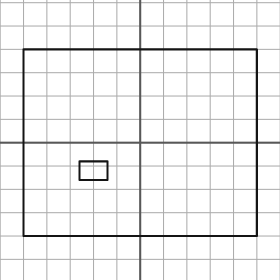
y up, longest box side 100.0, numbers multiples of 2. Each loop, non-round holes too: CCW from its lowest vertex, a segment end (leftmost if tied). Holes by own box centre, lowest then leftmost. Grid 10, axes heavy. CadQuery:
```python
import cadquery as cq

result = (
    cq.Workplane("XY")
    .moveTo(-50.0, -40.0)
    .lineTo(50.0, -40.0)
    .lineTo(50.0, 40.0)
    .lineTo(-50.0, 40.0)
    .close()
    .moveTo(-26.0, -16.0)
    .lineTo(-14.0, -16.0)
    .lineTo(-14.0, -8.0)
    .lineTo(-26.0, -8.0)
    .close()
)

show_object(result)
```